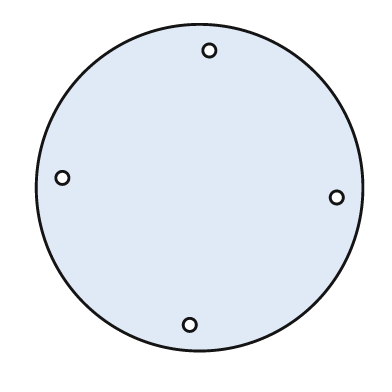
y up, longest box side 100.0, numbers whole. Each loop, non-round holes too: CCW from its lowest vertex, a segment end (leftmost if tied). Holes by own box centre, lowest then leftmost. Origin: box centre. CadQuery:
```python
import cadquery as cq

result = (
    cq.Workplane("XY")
    .moveTo(0.0, 0.0)
    .circle(50.0)
    .moveTo(-3.0, -42.0)
    .circle(2.0)
    .moveTo(42.0, -3.0)
    .circle(2.0)
    .moveTo(-42.0, 3.0)
    .circle(2.0)
    .moveTo(3.0, 42.0)
    .circle(2.0)
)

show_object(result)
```